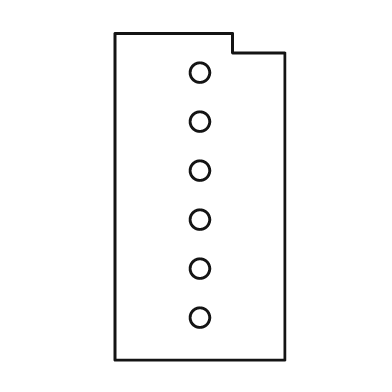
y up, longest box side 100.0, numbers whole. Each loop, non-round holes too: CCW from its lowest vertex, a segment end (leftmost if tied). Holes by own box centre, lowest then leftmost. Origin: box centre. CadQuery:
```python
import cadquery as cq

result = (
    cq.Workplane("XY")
    .moveTo(-26.0, -50.0)
    .lineTo(26.0, -50.0)
    .lineTo(26.0, 44.0)
    .lineTo(10.0, 44.0)
    .lineTo(10.0, 50.0)
    .lineTo(-26.0, 50.0)
    .close()
    .moveTo(0.0, -37.0)
    .circle(3.0)
    .moveTo(0.0, -22.0)
    .circle(3.0)
    .moveTo(0.0, -7.0)
    .circle(3.0)
    .moveTo(0.0, 8.0)
    .circle(3.0)
    .moveTo(0.0, 23.0)
    .circle(3.0)
    .moveTo(0.0, 38.0)
    .circle(3.0)
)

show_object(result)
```